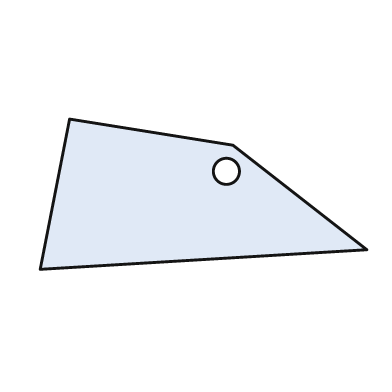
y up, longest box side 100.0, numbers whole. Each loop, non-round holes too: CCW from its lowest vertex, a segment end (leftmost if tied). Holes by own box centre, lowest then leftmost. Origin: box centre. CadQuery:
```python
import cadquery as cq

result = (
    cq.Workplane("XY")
    .moveTo(-50.0, -23.0)
    .lineTo(50.0, -17.0)
    .lineTo(9.0, 15.0)
    .lineTo(-41.0, 23.0)
    .close()
    .moveTo(7.0, 7.0)
    .circle(4.0)
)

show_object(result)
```